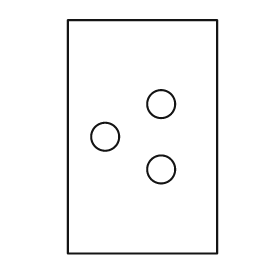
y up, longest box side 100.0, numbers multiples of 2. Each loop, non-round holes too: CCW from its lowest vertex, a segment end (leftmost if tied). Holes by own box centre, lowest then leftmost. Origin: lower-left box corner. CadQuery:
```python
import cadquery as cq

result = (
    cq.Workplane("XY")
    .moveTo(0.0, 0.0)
    .lineTo(64.0, 0.0)
    .lineTo(64.0, 100.0)
    .lineTo(0.0, 100.0)
    .close()
    .moveTo(40.0, 36.0)
    .circle(6.0)
    .moveTo(16.0, 50.0)
    .circle(6.0)
    .moveTo(40.0, 64.0)
    .circle(6.0)
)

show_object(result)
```